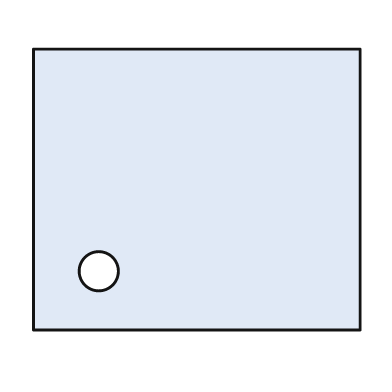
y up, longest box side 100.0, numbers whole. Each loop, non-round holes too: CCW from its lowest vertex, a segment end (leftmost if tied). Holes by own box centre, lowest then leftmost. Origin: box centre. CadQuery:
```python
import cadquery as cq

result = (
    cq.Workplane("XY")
    .moveTo(-50.0, -43.0)
    .lineTo(50.0, -43.0)
    .lineTo(50.0, 43.0)
    .lineTo(-50.0, 43.0)
    .close()
    .moveTo(-30.0, -25.0)
    .circle(6.0)
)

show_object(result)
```